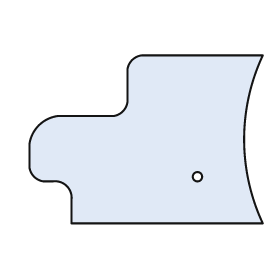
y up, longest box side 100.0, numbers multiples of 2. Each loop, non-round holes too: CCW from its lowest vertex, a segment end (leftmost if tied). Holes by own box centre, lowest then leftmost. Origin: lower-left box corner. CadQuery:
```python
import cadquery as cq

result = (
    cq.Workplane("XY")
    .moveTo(18.0, 0.0)
    .lineTo(100.0, 0.0)
    .threePointArc((92.0, 36.0), (100.0, 72.0))
    .lineTo(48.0, 72.0)
    .threePointArc((44.0, 70.0), (42.0, 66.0))
    .lineTo(42.0, 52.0)
    .threePointArc((40.0, 48.0), (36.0, 46.0))
    .lineTo(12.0, 46.0)
    .threePointArc((4.0, 42.0), (0.0, 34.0))
    .lineTo(0.0, 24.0)
    .threePointArc((2.0, 20.0), (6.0, 18.0))
    .lineTo(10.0, 18.0)
    .threePointArc((16.0, 16.0), (18.0, 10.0))
    .close()
    .moveTo(72.0, 20.0)
    .circle(2.0)
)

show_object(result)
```